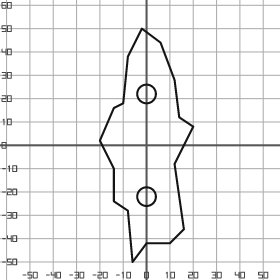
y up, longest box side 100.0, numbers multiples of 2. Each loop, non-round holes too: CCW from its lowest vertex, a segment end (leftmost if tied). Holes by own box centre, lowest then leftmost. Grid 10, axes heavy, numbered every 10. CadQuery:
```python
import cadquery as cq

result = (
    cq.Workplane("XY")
    .moveTo(-6.0, -50.0)
    .lineTo(0.0, -42.0)
    .lineTo(10.0, -42.0)
    .lineTo(16.0, -36.0)
    .lineTo(12.0, -8.0)
    .lineTo(20.0, 8.0)
    .lineTo(14.0, 12.0)
    .lineTo(12.0, 28.0)
    .lineTo(6.0, 44.0)
    .lineTo(-2.0, 50.0)
    .lineTo(-8.0, 38.0)
    .lineTo(-10.0, 18.0)
    .lineTo(-14.0, 16.0)
    .lineTo(-20.0, 2.0)
    .lineTo(-14.0, -10.0)
    .lineTo(-14.0, -24.0)
    .lineTo(-8.0, -28.0)
    .close()
    .moveTo(0.0, -22.0)
    .circle(4.0)
    .moveTo(0.0, 22.0)
    .circle(4.0)
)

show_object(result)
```